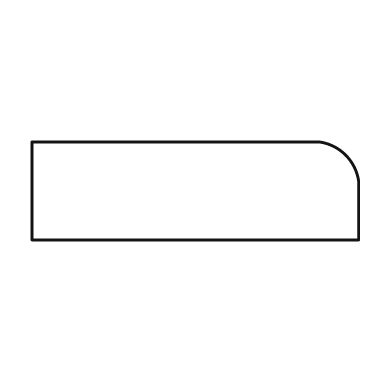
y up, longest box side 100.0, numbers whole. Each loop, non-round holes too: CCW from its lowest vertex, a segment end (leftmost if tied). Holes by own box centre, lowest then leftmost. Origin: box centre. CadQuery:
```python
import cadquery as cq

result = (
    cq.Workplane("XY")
    .moveTo(-50.0, -15.0)
    .lineTo(50.0, -15.0)
    .lineTo(50.0, 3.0)
    .threePointArc((46.0, 11.0), (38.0, 15.0))
    .lineTo(-50.0, 15.0)
    .close()
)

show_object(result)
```